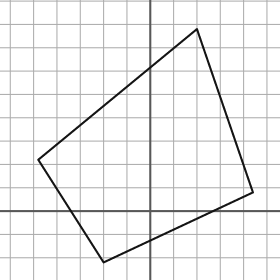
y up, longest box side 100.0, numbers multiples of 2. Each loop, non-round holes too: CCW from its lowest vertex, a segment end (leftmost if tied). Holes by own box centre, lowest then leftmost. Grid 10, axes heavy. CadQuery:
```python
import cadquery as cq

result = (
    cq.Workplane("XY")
    .moveTo(-20.0, -22.0)
    .lineTo(44.0, 8.0)
    .lineTo(20.0, 78.0)
    .lineTo(-48.0, 22.0)
    .close()
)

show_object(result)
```